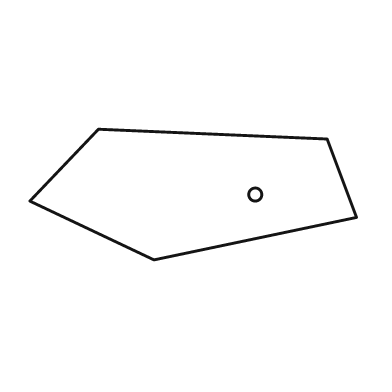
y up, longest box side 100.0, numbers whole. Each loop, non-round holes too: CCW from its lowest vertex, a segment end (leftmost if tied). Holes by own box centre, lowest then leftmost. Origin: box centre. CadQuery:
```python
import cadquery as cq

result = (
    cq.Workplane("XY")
    .moveTo(-12.0, -20.0)
    .lineTo(50.0, -7.0)
    .lineTo(41.0, 17.0)
    .lineTo(-29.0, 20.0)
    .lineTo(-50.0, -2.0)
    .close()
    .moveTo(19.0, 0.0)
    .circle(2.0)
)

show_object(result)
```